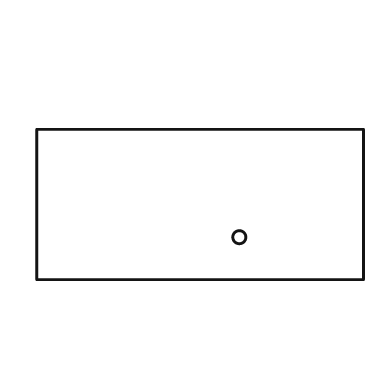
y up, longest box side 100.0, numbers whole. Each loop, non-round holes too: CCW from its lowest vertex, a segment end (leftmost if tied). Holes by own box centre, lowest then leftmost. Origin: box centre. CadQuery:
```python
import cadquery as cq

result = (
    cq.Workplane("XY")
    .moveTo(-50.0, -23.0)
    .lineTo(50.0, -23.0)
    .lineTo(50.0, 23.0)
    .lineTo(-50.0, 23.0)
    .close()
    .moveTo(12.0, -10.0)
    .circle(2.0)
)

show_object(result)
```